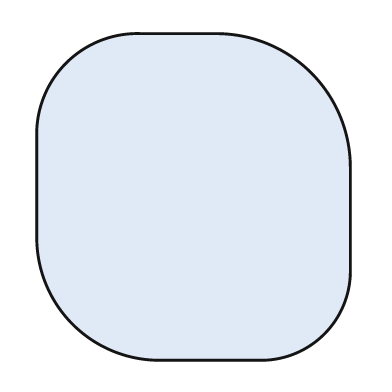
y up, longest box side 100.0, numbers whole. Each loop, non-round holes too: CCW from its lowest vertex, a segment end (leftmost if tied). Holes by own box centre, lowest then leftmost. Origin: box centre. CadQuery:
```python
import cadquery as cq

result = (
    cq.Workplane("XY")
    .moveTo(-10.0, -50.0)
    .lineTo(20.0, -50.0)
    .threePointArc((40.0, -42.0), (48.0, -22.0))
    .lineTo(48.0, 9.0)
    .threePointArc((36.0, 38.0), (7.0, 50.0))
    .lineTo(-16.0, 50.0)
    .threePointArc((-39.0, 41.0), (-48.0, 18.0))
    .lineTo(-48.0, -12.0)
    .threePointArc((-37.0, -39.0), (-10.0, -50.0))
    .close()
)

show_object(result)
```